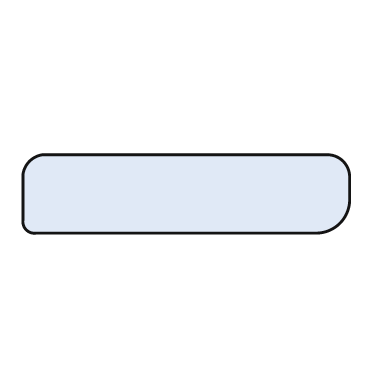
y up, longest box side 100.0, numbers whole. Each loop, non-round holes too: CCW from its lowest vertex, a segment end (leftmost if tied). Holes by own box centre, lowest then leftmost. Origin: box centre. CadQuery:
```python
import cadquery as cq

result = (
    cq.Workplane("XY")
    .moveTo(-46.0, -12.0)
    .lineTo(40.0, -12.0)
    .threePointArc((47.0, -9.0), (50.0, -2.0))
    .lineTo(50.0, 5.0)
    .threePointArc((48.0, 10.0), (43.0, 12.0))
    .lineTo(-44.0, 12.0)
    .threePointArc((-48.0, 10.0), (-50.0, 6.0))
    .lineTo(-50.0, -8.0)
    .threePointArc((-49.0, -11.0), (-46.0, -12.0))
    .close()
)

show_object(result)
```